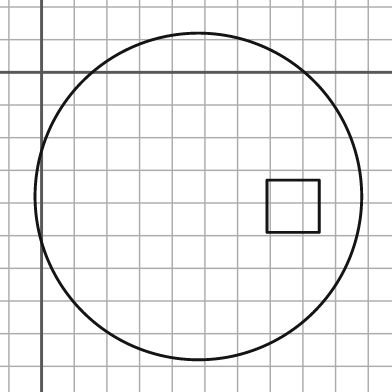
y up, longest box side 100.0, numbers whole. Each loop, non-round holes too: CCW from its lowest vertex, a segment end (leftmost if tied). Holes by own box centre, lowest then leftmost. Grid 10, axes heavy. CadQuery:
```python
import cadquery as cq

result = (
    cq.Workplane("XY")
    .moveTo(48.0, -38.0)
    .circle(50.0)
    .moveTo(69.0, -49.0)
    .lineTo(85.0, -49.0)
    .lineTo(85.0, -33.0)
    .lineTo(69.0, -33.0)
    .close()
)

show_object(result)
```